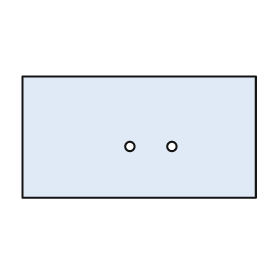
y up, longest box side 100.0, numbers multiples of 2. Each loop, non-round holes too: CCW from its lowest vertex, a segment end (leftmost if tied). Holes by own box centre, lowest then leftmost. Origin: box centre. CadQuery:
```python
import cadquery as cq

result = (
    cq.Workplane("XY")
    .moveTo(-50.0, -26.0)
    .lineTo(50.0, -26.0)
    .lineTo(50.0, 26.0)
    .lineTo(-50.0, 26.0)
    .close()
    .moveTo(-4.0, -4.0)
    .circle(2.0)
    .moveTo(14.0, -4.0)
    .circle(2.0)
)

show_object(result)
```